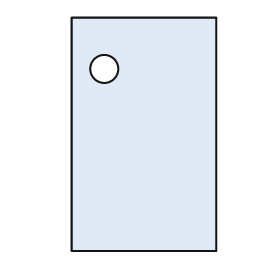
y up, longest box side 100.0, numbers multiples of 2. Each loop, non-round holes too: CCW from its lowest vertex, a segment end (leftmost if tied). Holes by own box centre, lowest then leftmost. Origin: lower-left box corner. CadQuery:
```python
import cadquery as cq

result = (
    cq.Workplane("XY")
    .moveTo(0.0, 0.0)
    .lineTo(62.0, 0.0)
    .lineTo(62.0, 100.0)
    .lineTo(0.0, 100.0)
    .close()
    .moveTo(14.0, 78.0)
    .circle(6.0)
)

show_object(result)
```